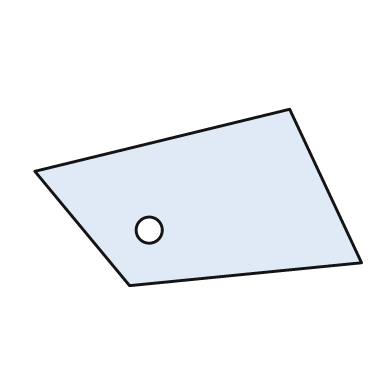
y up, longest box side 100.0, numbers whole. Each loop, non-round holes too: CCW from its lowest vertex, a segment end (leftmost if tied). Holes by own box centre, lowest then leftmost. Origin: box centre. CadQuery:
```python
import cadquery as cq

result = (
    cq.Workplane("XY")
    .moveTo(-21.0, -27.0)
    .lineTo(50.0, -20.0)
    .lineTo(28.0, 27.0)
    .lineTo(-50.0, 8.0)
    .close()
    .moveTo(-15.0, -10.0)
    .circle(4.0)
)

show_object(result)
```